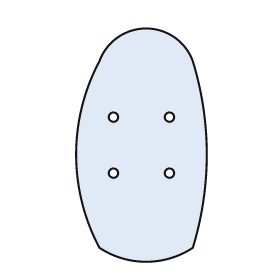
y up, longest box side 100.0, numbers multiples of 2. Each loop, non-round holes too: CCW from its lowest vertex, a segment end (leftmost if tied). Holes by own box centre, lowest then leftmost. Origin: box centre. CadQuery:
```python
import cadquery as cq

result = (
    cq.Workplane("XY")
    .moveTo(-18.0, -44.0)
    .threePointArc((2.0, -50.0), (22.0, -44.0))
    .threePointArc((28.0, -4.0), (22.0, 36.0))
    .threePointArc((2.0, 50.0), (-18.0, 36.0))
    .threePointArc((-28.0, -4.0), (-18.0, -44.0))
    .close()
    .moveTo(-12.0, -12.0)
    .circle(2.0)
    .moveTo(12.0, -12.0)
    .circle(2.0)
    .moveTo(-12.0, 12.0)
    .circle(2.0)
    .moveTo(12.0, 12.0)
    .circle(2.0)
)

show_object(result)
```